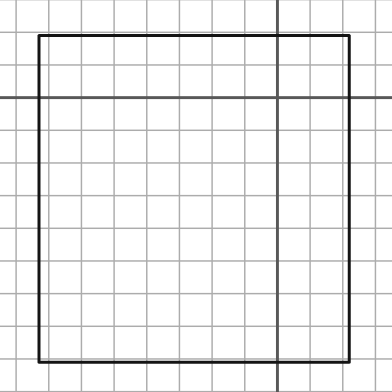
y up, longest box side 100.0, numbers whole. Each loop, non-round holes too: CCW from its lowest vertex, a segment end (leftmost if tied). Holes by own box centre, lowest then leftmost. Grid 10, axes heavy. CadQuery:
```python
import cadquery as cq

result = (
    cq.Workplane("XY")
    .moveTo(-73.0, -81.0)
    .lineTo(22.0, -81.0)
    .lineTo(22.0, 19.0)
    .lineTo(-73.0, 19.0)
    .close()
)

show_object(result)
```